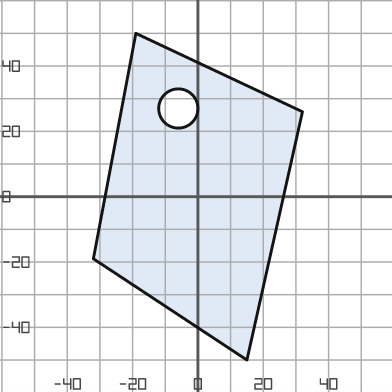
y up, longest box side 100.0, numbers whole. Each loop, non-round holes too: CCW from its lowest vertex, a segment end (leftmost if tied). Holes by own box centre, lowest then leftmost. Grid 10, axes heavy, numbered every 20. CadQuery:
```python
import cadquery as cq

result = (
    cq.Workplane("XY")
    .moveTo(15.0, -50.0)
    .lineTo(32.0, 26.0)
    .lineTo(-19.0, 50.0)
    .lineTo(-32.0, -19.0)
    .close()
    .moveTo(-6.0, 27.0)
    .circle(6.0)
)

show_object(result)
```